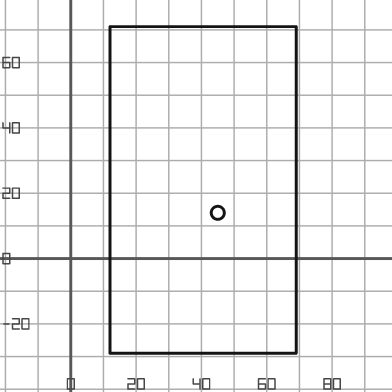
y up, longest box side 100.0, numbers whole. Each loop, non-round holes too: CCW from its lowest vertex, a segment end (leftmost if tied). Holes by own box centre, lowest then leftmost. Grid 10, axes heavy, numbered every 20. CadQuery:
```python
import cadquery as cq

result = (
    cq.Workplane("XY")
    .moveTo(12.0, -29.0)
    .lineTo(69.0, -29.0)
    .lineTo(69.0, 71.0)
    .lineTo(12.0, 71.0)
    .close()
    .moveTo(45.0, 14.0)
    .circle(2.0)
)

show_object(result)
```